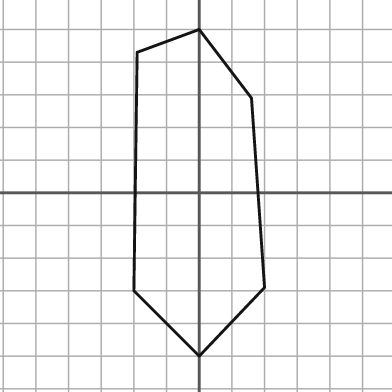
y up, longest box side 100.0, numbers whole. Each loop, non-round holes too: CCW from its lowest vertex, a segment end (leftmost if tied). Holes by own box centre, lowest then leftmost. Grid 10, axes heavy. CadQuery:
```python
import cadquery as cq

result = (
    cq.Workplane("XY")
    .moveTo(0.0, -50.0)
    .lineTo(20.0, -29.0)
    .lineTo(16.0, 29.0)
    .lineTo(0.0, 50.0)
    .lineTo(-19.0, 43.0)
    .lineTo(-20.0, -30.0)
    .close()
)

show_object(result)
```